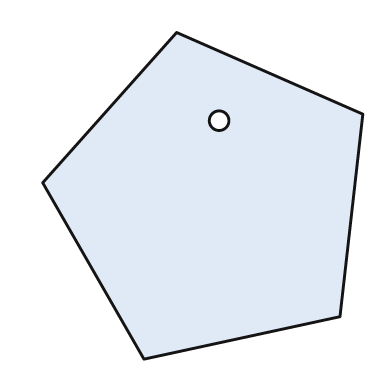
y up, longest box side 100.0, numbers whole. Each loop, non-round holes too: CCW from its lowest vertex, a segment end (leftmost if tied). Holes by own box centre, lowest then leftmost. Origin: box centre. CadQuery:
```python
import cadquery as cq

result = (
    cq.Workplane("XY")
    .moveTo(-18.0, -50.0)
    .lineTo(42.0, -37.0)
    .lineTo(49.0, 25.0)
    .lineTo(-8.0, 50.0)
    .lineTo(-49.0, 4.0)
    .close()
    .moveTo(5.0, 23.0)
    .circle(3.0)
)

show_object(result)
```